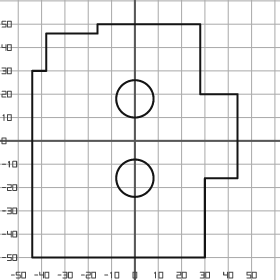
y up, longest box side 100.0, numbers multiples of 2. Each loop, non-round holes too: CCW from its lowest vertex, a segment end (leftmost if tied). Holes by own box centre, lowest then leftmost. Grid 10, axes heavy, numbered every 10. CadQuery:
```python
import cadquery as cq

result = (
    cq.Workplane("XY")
    .moveTo(-44.0, -50.0)
    .lineTo(30.0, -50.0)
    .lineTo(30.0, -16.0)
    .lineTo(44.0, -16.0)
    .lineTo(44.0, 20.0)
    .lineTo(28.0, 20.0)
    .lineTo(28.0, 50.0)
    .lineTo(-16.0, 50.0)
    .lineTo(-16.0, 46.0)
    .lineTo(-38.0, 46.0)
    .lineTo(-38.0, 30.0)
    .lineTo(-44.0, 30.0)
    .close()
    .moveTo(0.0, -16.0)
    .circle(8.0)
    .moveTo(0.0, 18.0)
    .circle(8.0)
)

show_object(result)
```